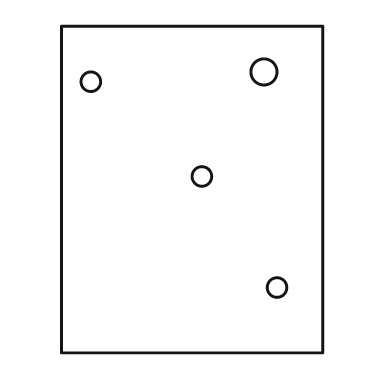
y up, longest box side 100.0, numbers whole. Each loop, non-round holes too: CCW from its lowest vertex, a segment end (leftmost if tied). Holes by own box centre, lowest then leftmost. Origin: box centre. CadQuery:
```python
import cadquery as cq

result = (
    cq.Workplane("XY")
    .moveTo(-40.0, -50.0)
    .lineTo(40.0, -50.0)
    .lineTo(40.0, 50.0)
    .lineTo(-40.0, 50.0)
    .close()
    .moveTo(26.0, -30.0)
    .circle(3.0)
    .moveTo(3.0, 4.0)
    .circle(3.0)
    .moveTo(-31.0, 33.0)
    .circle(3.0)
    .moveTo(22.0, 36.0)
    .circle(4.0)
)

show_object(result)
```